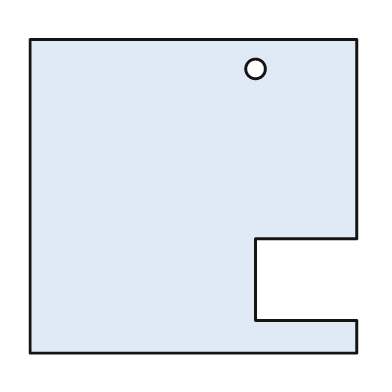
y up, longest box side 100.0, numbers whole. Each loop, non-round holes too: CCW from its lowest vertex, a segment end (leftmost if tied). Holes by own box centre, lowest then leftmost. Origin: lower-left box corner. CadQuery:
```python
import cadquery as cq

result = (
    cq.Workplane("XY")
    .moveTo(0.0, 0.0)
    .lineTo(100.0, 0.0)
    .lineTo(100.0, 10.0)
    .lineTo(69.0, 10.0)
    .lineTo(69.0, 35.0)
    .lineTo(100.0, 35.0)
    .lineTo(100.0, 96.0)
    .lineTo(0.0, 96.0)
    .close()
    .moveTo(69.0, 87.0)
    .circle(3.0)
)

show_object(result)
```